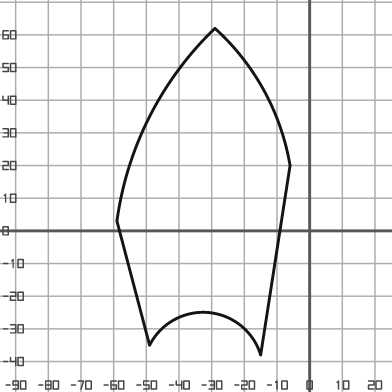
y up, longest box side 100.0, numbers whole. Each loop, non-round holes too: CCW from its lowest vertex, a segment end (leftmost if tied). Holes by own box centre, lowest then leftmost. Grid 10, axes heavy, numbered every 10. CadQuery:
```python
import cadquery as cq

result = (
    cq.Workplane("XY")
    .moveTo(-15.0, -38.0)
    .lineTo(-6.0, 20.0)
    .threePointArc((-14.0, 43.0), (-29.0, 62.0))
    .threePointArc((-49.0, 35.0), (-59.0, 3.0))
    .lineTo(-49.0, -35.0)
    .threePointArc((-31.0, -25.0), (-15.0, -38.0))
    .close()
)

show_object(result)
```